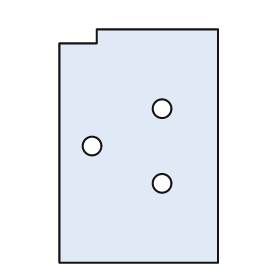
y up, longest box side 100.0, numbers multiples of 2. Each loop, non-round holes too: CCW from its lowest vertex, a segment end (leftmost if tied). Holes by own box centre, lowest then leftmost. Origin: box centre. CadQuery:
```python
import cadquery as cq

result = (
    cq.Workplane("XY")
    .moveTo(-34.0, -50.0)
    .lineTo(34.0, -50.0)
    .lineTo(34.0, 50.0)
    .lineTo(-18.0, 50.0)
    .lineTo(-18.0, 44.0)
    .lineTo(-34.0, 44.0)
    .close()
    .moveTo(10.0, -16.0)
    .circle(4.0)
    .moveTo(-20.0, 0.0)
    .circle(4.0)
    .moveTo(10.0, 16.0)
    .circle(4.0)
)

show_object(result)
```